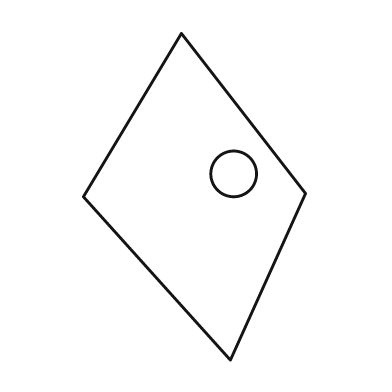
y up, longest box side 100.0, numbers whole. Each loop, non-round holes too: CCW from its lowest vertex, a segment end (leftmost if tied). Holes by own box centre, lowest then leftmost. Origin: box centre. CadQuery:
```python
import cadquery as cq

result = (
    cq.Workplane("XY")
    .moveTo(11.0, -50.0)
    .lineTo(34.0, 1.0)
    .lineTo(-4.0, 50.0)
    .lineTo(-34.0, 0.0)
    .close()
    .moveTo(12.0, 7.0)
    .circle(7.0)
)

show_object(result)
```